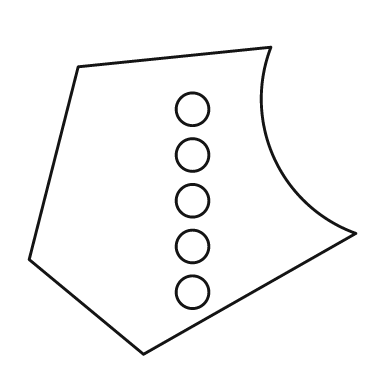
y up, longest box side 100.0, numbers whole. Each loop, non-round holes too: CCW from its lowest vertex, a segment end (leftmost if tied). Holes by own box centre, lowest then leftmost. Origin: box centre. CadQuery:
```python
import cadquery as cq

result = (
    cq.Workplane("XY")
    .moveTo(-15.0, -47.0)
    .lineTo(50.0, -10.0)
    .threePointArc((25.0, 13.0), (24.0, 47.0))
    .lineTo(-35.0, 41.0)
    .lineTo(-50.0, -18.0)
    .close()
    .moveTo(0.0, -28.0)
    .circle(5.0)
    .moveTo(0.0, -14.0)
    .circle(5.0)
    .moveTo(0.0, 0.0)
    .circle(5.0)
    .moveTo(0.0, 14.0)
    .circle(5.0)
    .moveTo(0.0, 28.0)
    .circle(5.0)
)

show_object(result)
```